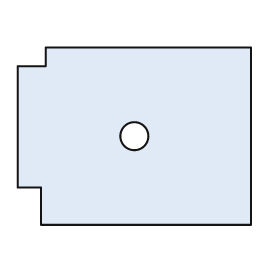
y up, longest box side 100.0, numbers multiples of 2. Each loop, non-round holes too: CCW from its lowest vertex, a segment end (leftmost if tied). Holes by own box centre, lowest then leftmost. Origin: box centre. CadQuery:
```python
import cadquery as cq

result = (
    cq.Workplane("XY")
    .moveTo(-40.0, -38.0)
    .lineTo(50.0, -38.0)
    .lineTo(50.0, 38.0)
    .lineTo(-38.0, 38.0)
    .lineTo(-38.0, 30.0)
    .lineTo(-50.0, 30.0)
    .lineTo(-50.0, -22.0)
    .lineTo(-40.0, -22.0)
    .close()
    .moveTo(0.0, 0.0)
    .circle(6.0)
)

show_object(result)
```